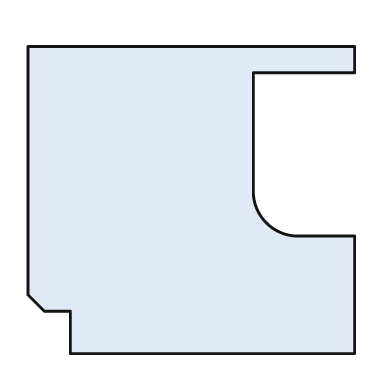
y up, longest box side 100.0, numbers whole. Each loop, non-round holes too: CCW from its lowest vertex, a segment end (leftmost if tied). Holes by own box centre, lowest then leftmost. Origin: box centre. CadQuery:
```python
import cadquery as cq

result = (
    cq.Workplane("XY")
    .moveTo(-37.0, -47.0)
    .lineTo(50.0, -47.0)
    .lineTo(50.0, -11.0)
    .lineTo(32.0, -11.0)
    .threePointArc((23.0, -7.0), (19.0, 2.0))
    .lineTo(19.0, 39.0)
    .lineTo(50.0, 39.0)
    .lineTo(50.0, 47.0)
    .lineTo(-50.0, 47.0)
    .lineTo(-50.0, -29.0)
    .lineTo(-45.0, -34.0)
    .lineTo(-37.0, -34.0)
    .close()
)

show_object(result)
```